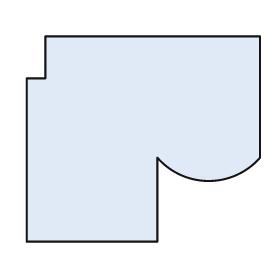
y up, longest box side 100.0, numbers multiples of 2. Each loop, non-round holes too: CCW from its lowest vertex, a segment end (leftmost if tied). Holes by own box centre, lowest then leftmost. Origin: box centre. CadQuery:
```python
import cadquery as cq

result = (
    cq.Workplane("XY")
    .moveTo(-50.0, -44.0)
    .lineTo(6.0, -44.0)
    .lineTo(6.0, -8.0)
    .threePointArc((28.0, -18.0), (50.0, -8.0))
    .lineTo(50.0, 44.0)
    .lineTo(-42.0, 44.0)
    .lineTo(-42.0, 26.0)
    .lineTo(-50.0, 26.0)
    .close()
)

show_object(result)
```